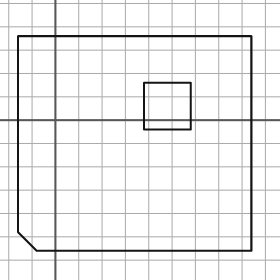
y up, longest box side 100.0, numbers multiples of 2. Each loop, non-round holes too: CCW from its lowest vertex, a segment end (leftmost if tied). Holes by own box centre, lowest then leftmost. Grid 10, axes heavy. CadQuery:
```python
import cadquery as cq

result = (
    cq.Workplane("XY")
    .moveTo(-8.0, -56.0)
    .lineTo(84.0, -56.0)
    .lineTo(84.0, 36.0)
    .lineTo(-16.0, 36.0)
    .lineTo(-16.0, -48.0)
    .close()
    .moveTo(38.0, -4.0)
    .lineTo(58.0, -4.0)
    .lineTo(58.0, 16.0)
    .lineTo(38.0, 16.0)
    .close()
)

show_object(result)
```